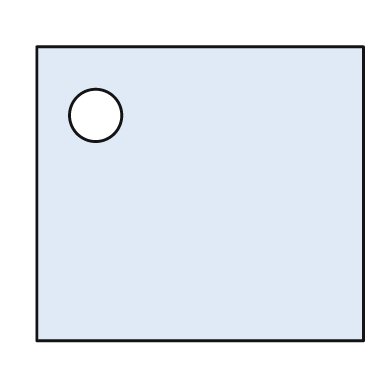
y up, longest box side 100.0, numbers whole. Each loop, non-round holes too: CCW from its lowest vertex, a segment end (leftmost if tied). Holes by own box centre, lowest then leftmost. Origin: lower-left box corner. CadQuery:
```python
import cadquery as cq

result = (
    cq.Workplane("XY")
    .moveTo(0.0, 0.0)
    .lineTo(100.0, 0.0)
    .lineTo(100.0, 90.0)
    .lineTo(0.0, 90.0)
    .close()
    .moveTo(18.0, 69.0)
    .circle(8.0)
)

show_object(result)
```